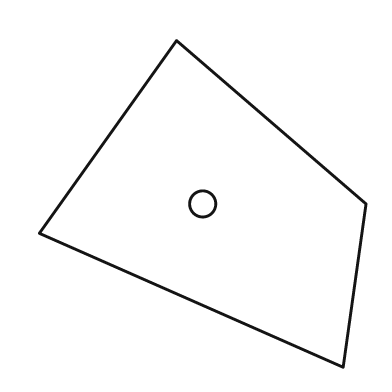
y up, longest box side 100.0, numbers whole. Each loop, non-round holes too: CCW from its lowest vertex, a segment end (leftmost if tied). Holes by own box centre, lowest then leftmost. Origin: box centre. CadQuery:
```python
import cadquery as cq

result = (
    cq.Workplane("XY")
    .moveTo(43.0, -50.0)
    .lineTo(50.0, 0.0)
    .lineTo(-8.0, 50.0)
    .lineTo(-50.0, -9.0)
    .close()
    .moveTo(0.0, 0.0)
    .circle(4.0)
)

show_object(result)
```